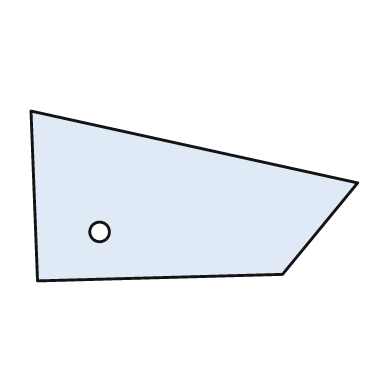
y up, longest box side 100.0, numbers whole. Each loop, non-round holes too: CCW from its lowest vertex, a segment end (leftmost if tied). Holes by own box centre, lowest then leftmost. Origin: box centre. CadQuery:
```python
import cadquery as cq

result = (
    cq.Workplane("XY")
    .moveTo(-48.0, -26.0)
    .lineTo(27.0, -24.0)
    .lineTo(50.0, 4.0)
    .lineTo(-50.0, 26.0)
    .close()
    .moveTo(-29.0, -11.0)
    .circle(3.0)
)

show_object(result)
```